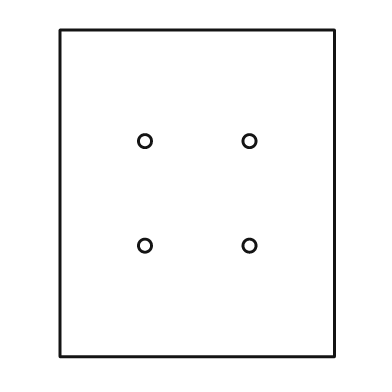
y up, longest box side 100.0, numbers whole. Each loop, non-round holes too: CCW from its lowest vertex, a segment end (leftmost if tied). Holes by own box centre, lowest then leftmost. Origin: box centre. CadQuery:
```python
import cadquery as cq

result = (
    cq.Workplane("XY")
    .moveTo(-42.0, -50.0)
    .lineTo(42.0, -50.0)
    .lineTo(42.0, 50.0)
    .lineTo(-42.0, 50.0)
    .close()
    .moveTo(-16.0, -16.0)
    .circle(2.0)
    .moveTo(16.0, -16.0)
    .circle(2.0)
    .moveTo(-16.0, 16.0)
    .circle(2.0)
    .moveTo(16.0, 16.0)
    .circle(2.0)
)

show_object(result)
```